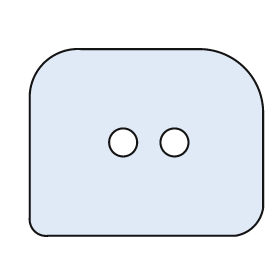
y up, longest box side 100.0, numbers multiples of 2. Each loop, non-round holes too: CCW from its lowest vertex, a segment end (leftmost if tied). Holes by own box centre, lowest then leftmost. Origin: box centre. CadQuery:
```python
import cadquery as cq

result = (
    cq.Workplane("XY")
    .moveTo(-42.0, -40.0)
    .lineTo(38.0, -40.0)
    .threePointArc((46.0, -36.0), (50.0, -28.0))
    .lineTo(50.0, 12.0)
    .threePointArc((42.0, 32.0), (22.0, 40.0))
    .lineTo(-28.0, 40.0)
    .threePointArc((-44.0, 34.0), (-50.0, 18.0))
    .lineTo(-50.0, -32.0)
    .threePointArc((-48.0, -38.0), (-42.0, -40.0))
    .close()
    .moveTo(-10.0, 0.0)
    .circle(6.0)
    .moveTo(12.0, 0.0)
    .circle(6.0)
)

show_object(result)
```